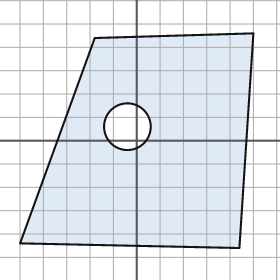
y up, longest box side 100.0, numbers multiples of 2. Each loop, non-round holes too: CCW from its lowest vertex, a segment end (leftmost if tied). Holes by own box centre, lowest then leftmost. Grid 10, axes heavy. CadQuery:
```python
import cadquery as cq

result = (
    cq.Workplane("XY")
    .moveTo(44.0, -46.0)
    .lineTo(50.0, 46.0)
    .lineTo(-18.0, 44.0)
    .lineTo(-50.0, -44.0)
    .close()
    .moveTo(-4.0, 6.0)
    .circle(10.0)
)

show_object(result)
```